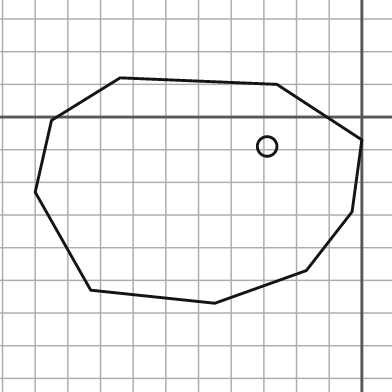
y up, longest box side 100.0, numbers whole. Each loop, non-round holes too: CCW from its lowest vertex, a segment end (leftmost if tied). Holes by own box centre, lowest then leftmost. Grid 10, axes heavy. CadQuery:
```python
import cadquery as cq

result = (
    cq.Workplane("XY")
    .moveTo(-45.0, -57.0)
    .lineTo(-17.0, -47.0)
    .lineTo(-3.0, -29.0)
    .lineTo(0.0, -7.0)
    .lineTo(-26.0, 10.0)
    .lineTo(-74.0, 12.0)
    .lineTo(-95.0, -1.0)
    .lineTo(-100.0, -23.0)
    .lineTo(-83.0, -53.0)
    .close()
    .moveTo(-29.0, -9.0)
    .circle(3.0)
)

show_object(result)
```